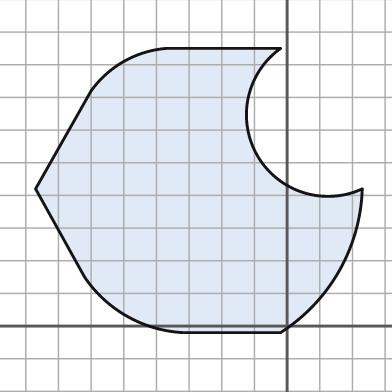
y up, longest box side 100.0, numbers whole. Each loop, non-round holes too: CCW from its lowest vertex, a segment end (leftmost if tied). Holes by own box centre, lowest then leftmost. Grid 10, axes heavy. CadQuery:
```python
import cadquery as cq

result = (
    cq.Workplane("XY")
    .moveTo(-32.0, -2.0)
    .lineTo(-2.0, -2.0)
    .threePointArc((16.0, 17.0), (23.0, 42.0))
    .threePointArc((-9.0, 52.0), (-2.0, 85.0))
    .lineTo(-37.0, 85.0)
    .threePointArc((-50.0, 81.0), (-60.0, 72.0))
    .lineTo(-77.0, 42.0)
    .lineTo(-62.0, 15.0)
    .threePointArc((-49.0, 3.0), (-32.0, -2.0))
    .close()
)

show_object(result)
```